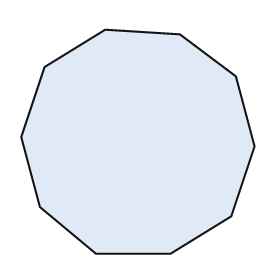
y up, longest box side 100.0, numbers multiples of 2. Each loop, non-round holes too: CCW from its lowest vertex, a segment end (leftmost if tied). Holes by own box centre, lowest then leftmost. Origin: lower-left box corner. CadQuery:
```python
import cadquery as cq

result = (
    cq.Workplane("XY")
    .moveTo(32.0, 0.0)
    .lineTo(64.0, 0.0)
    .lineTo(90.0, 16.0)
    .lineTo(100.0, 46.0)
    .lineTo(92.0, 76.0)
    .lineTo(68.0, 94.0)
    .lineTo(36.0, 96.0)
    .lineTo(10.0, 80.0)
    .lineTo(0.0, 50.0)
    .lineTo(8.0, 20.0)
    .close()
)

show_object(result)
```